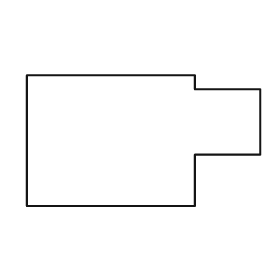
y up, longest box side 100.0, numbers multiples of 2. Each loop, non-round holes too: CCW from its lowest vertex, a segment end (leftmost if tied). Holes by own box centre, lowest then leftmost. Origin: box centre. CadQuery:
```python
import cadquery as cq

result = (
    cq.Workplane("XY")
    .moveTo(-50.0, -28.0)
    .lineTo(22.0, -28.0)
    .lineTo(22.0, -6.0)
    .lineTo(50.0, -6.0)
    .lineTo(50.0, 22.0)
    .lineTo(22.0, 22.0)
    .lineTo(22.0, 28.0)
    .lineTo(-50.0, 28.0)
    .close()
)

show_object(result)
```